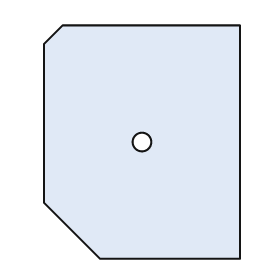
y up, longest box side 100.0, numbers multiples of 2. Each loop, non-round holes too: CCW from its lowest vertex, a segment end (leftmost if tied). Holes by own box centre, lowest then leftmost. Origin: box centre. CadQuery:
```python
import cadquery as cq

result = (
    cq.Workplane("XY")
    .moveTo(-18.0, -50.0)
    .lineTo(42.0, -50.0)
    .lineTo(42.0, 50.0)
    .lineTo(-34.0, 50.0)
    .lineTo(-42.0, 42.0)
    .lineTo(-42.0, -26.0)
    .close()
    .moveTo(0.0, 0.0)
    .circle(4.0)
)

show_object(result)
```